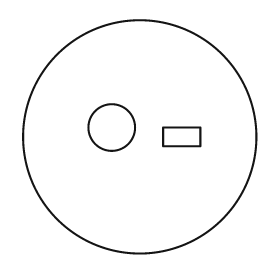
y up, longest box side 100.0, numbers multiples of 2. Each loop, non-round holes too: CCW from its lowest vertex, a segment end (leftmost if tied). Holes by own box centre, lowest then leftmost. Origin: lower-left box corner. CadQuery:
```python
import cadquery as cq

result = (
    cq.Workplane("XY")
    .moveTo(50.0, 50.0)
    .circle(50.0)
    .moveTo(60.0, 46.0)
    .lineTo(76.0, 46.0)
    .lineTo(76.0, 54.0)
    .lineTo(60.0, 54.0)
    .close()
    .moveTo(38.0, 54.0)
    .circle(10.0)
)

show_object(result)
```